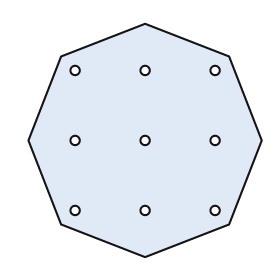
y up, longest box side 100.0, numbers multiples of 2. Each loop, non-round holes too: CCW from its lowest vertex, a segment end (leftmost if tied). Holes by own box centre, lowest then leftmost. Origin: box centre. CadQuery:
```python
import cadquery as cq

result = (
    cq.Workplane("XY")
    .moveTo(0.0, -50.0)
    .lineTo(36.0, -36.0)
    .lineTo(50.0, 0.0)
    .lineTo(36.0, 36.0)
    .lineTo(0.0, 50.0)
    .lineTo(-36.0, 36.0)
    .lineTo(-50.0, 0.0)
    .lineTo(-36.0, -36.0)
    .close()
    .moveTo(-30.0, -30.0)
    .circle(2.0)
    .moveTo(0.0, -30.0)
    .circle(2.0)
    .moveTo(30.0, -30.0)
    .circle(2.0)
    .moveTo(-30.0, 0.0)
    .circle(2.0)
    .moveTo(0.0, 0.0)
    .circle(2.0)
    .moveTo(30.0, 0.0)
    .circle(2.0)
    .moveTo(-30.0, 30.0)
    .circle(2.0)
    .moveTo(0.0, 30.0)
    .circle(2.0)
    .moveTo(30.0, 30.0)
    .circle(2.0)
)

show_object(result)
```